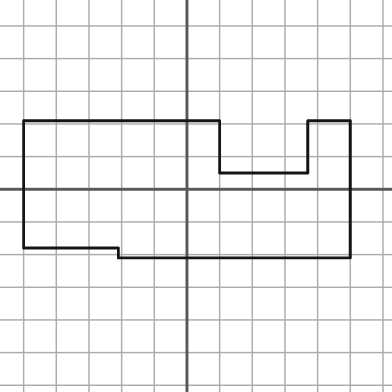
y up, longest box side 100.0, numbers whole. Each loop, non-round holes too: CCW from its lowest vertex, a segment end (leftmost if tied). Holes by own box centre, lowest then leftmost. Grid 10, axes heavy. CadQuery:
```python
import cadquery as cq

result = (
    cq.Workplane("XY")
    .moveTo(-21.0, -21.0)
    .lineTo(50.0, -21.0)
    .lineTo(50.0, 21.0)
    .lineTo(37.0, 21.0)
    .lineTo(37.0, 5.0)
    .lineTo(10.0, 5.0)
    .lineTo(10.0, 21.0)
    .lineTo(-50.0, 21.0)
    .lineTo(-50.0, -18.0)
    .lineTo(-21.0, -18.0)
    .close()
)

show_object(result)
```